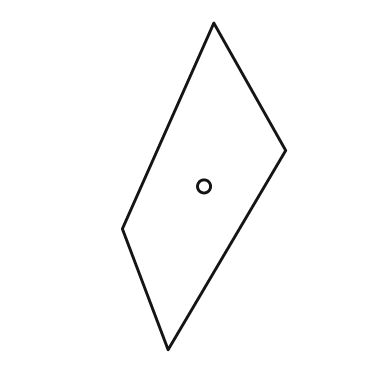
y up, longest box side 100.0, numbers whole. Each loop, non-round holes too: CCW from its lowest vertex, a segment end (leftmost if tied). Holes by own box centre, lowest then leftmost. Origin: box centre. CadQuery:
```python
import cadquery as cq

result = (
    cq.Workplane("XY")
    .moveTo(-11.0, -50.0)
    .lineTo(25.0, 11.0)
    .lineTo(3.0, 50.0)
    .lineTo(-25.0, -13.0)
    .close()
    .moveTo(0.0, 0.0)
    .circle(2.0)
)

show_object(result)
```